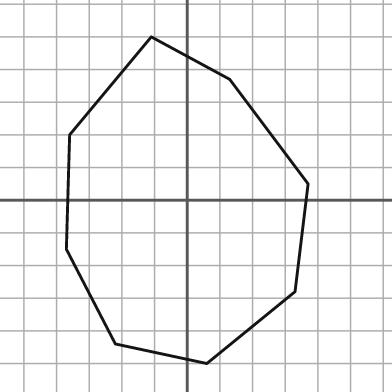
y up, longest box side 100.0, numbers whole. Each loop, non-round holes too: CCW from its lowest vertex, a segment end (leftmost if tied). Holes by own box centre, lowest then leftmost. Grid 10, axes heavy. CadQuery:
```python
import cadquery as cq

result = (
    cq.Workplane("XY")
    .moveTo(6.0, -50.0)
    .lineTo(33.0, -28.0)
    .lineTo(37.0, 5.0)
    .lineTo(13.0, 37.0)
    .lineTo(-11.0, 50.0)
    .lineTo(-36.0, 20.0)
    .lineTo(-37.0, -15.0)
    .lineTo(-22.0, -44.0)
    .close()
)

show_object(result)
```